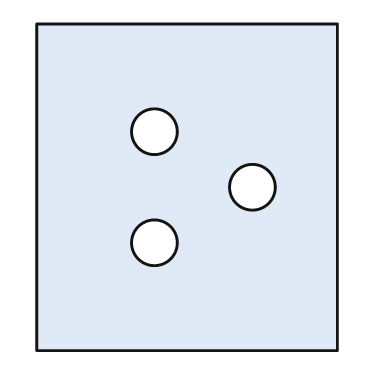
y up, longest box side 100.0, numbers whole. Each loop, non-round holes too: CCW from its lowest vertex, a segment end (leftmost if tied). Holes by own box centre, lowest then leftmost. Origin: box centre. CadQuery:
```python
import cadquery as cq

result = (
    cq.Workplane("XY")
    .moveTo(-46.0, -50.0)
    .lineTo(46.0, -50.0)
    .lineTo(46.0, 50.0)
    .lineTo(-46.0, 50.0)
    .close()
    .moveTo(-10.0, -17.0)
    .circle(7.0)
    .moveTo(20.0, 0.0)
    .circle(7.0)
    .moveTo(-10.0, 17.0)
    .circle(7.0)
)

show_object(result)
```